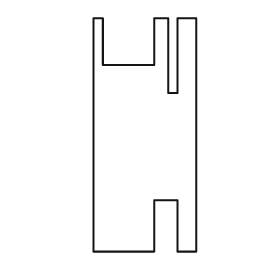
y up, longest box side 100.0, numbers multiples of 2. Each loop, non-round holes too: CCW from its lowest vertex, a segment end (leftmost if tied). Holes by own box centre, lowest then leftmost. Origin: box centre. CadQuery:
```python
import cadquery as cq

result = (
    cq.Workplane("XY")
    .moveTo(-22.0, -50.0)
    .lineTo(4.0, -50.0)
    .lineTo(4.0, -28.0)
    .lineTo(14.0, -28.0)
    .lineTo(14.0, -50.0)
    .lineTo(22.0, -50.0)
    .lineTo(22.0, 50.0)
    .lineTo(14.0, 50.0)
    .lineTo(14.0, 18.0)
    .lineTo(10.0, 18.0)
    .lineTo(10.0, 50.0)
    .lineTo(4.0, 50.0)
    .lineTo(4.0, 30.0)
    .lineTo(-18.0, 30.0)
    .lineTo(-18.0, 50.0)
    .lineTo(-22.0, 50.0)
    .close()
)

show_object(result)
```